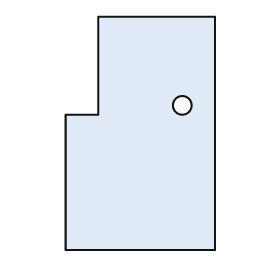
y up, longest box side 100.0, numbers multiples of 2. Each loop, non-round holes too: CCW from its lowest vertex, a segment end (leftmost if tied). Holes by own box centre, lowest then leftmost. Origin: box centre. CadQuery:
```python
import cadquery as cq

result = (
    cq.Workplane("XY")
    .moveTo(-32.0, -50.0)
    .lineTo(32.0, -50.0)
    .lineTo(32.0, 50.0)
    .lineTo(-18.0, 50.0)
    .lineTo(-18.0, 8.0)
    .lineTo(-32.0, 8.0)
    .close()
    .moveTo(18.0, 12.0)
    .circle(4.0)
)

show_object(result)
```